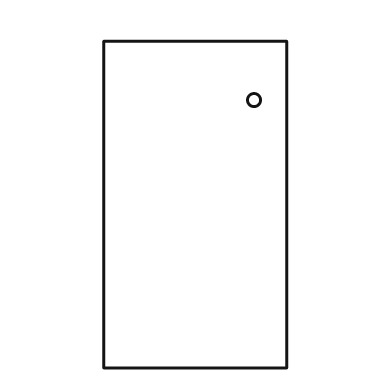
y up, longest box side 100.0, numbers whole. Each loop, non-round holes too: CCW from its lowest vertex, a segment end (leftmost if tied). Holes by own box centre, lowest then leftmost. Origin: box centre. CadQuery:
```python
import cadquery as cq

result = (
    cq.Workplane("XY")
    .moveTo(-28.0, -50.0)
    .lineTo(28.0, -50.0)
    .lineTo(28.0, 50.0)
    .lineTo(-28.0, 50.0)
    .close()
    .moveTo(18.0, 32.0)
    .circle(2.0)
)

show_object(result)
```